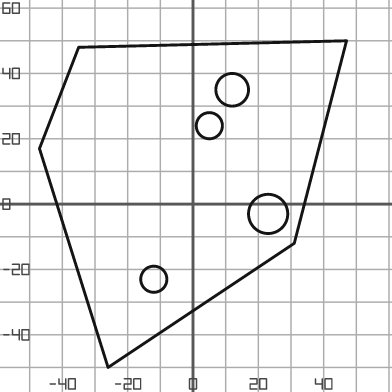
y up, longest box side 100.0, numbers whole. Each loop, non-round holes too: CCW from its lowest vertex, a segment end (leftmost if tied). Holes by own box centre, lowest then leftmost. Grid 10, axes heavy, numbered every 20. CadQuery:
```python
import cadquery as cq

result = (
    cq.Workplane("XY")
    .moveTo(-26.0, -50.0)
    .lineTo(31.0, -12.0)
    .lineTo(47.0, 50.0)
    .lineTo(-35.0, 48.0)
    .lineTo(-47.0, 17.0)
    .close()
    .moveTo(-12.0, -23.0)
    .circle(4.0)
    .moveTo(23.0, -3.0)
    .circle(6.0)
    .moveTo(5.0, 24.0)
    .circle(4.0)
    .moveTo(12.0, 35.0)
    .circle(5.0)
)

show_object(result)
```